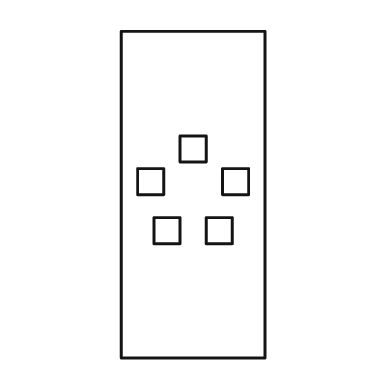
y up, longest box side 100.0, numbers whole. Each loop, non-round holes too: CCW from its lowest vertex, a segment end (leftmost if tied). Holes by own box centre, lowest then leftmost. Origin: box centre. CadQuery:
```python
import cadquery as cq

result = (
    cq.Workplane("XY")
    .moveTo(-22.0, -50.0)
    .lineTo(22.0, -50.0)
    .lineTo(22.0, 50.0)
    .lineTo(-22.0, 50.0)
    .close()
    .moveTo(-12.0, -15.0)
    .lineTo(-4.0, -15.0)
    .lineTo(-4.0, -7.0)
    .lineTo(-12.0, -7.0)
    .close()
    .moveTo(4.0, -15.0)
    .lineTo(12.0, -15.0)
    .lineTo(12.0, -7.0)
    .lineTo(4.0, -7.0)
    .close()
    .moveTo(-17.0, 0.0)
    .lineTo(-9.0, 0.0)
    .lineTo(-9.0, 8.0)
    .lineTo(-17.0, 8.0)
    .close()
    .moveTo(9.0, 0.0)
    .lineTo(17.0, 0.0)
    .lineTo(17.0, 8.0)
    .lineTo(9.0, 8.0)
    .close()
    .moveTo(-4.0, 10.0)
    .lineTo(4.0, 10.0)
    .lineTo(4.0, 18.0)
    .lineTo(-4.0, 18.0)
    .close()
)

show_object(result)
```